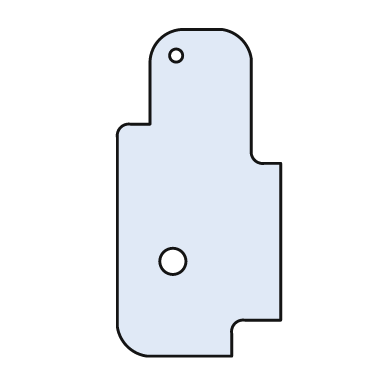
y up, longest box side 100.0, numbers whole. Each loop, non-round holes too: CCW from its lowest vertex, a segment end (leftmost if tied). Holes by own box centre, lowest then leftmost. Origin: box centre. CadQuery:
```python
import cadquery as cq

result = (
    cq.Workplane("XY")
    .moveTo(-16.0, -50.0)
    .lineTo(10.0, -50.0)
    .lineTo(10.0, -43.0)
    .threePointArc((11.0, -40.0), (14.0, -39.0))
    .lineTo(25.0, -39.0)
    .lineTo(25.0, 9.0)
    .lineTo(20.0, 9.0)
    .threePointArc((17.0, 10.0), (16.0, 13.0))
    .lineTo(16.0, 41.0)
    .threePointArc((13.0, 47.0), (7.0, 50.0))
    .lineTo(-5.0, 50.0)
    .threePointArc((-12.0, 47.0), (-15.0, 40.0))
    .lineTo(-15.0, 21.0)
    .lineTo(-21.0, 21.0)
    .threePointArc((-24.0, 20.0), (-25.0, 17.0))
    .lineTo(-25.0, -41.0)
    .threePointArc((-22.0, -47.0), (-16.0, -50.0))
    .close()
    .moveTo(-8.0, -21.0)
    .circle(4.0)
    .moveTo(-7.0, 42.0)
    .circle(2.0)
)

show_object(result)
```